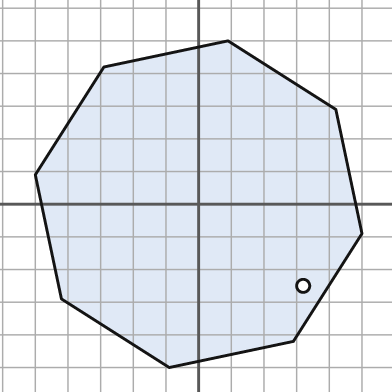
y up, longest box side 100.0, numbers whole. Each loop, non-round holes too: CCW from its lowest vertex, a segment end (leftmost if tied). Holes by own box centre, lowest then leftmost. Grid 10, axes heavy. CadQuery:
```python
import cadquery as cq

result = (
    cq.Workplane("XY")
    .moveTo(-9.0, -50.0)
    .lineTo(29.0, -42.0)
    .lineTo(50.0, -9.0)
    .lineTo(42.0, 29.0)
    .lineTo(9.0, 50.0)
    .lineTo(-29.0, 42.0)
    .lineTo(-50.0, 9.0)
    .lineTo(-42.0, -29.0)
    .close()
    .moveTo(32.0, -25.0)
    .circle(2.0)
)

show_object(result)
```